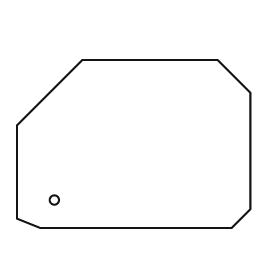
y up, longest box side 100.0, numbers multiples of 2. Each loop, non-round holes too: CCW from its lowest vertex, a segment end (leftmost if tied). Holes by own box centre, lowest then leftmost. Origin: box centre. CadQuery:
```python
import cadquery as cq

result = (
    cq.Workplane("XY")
    .moveTo(-40.0, -36.0)
    .lineTo(42.0, -36.0)
    .lineTo(50.0, -28.0)
    .lineTo(50.0, 22.0)
    .lineTo(36.0, 36.0)
    .lineTo(-22.0, 36.0)
    .lineTo(-50.0, 8.0)
    .lineTo(-50.0, -32.0)
    .close()
    .moveTo(-34.0, -24.0)
    .circle(2.0)
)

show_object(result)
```